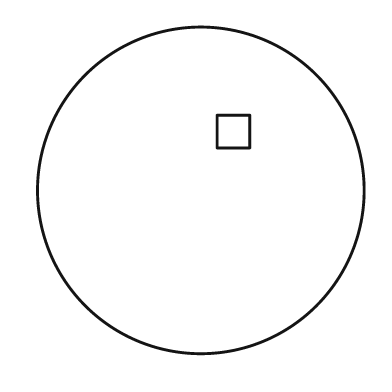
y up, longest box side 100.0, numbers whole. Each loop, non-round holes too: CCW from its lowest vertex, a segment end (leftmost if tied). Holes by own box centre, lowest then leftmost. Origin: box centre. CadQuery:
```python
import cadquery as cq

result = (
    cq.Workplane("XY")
    .moveTo(0.0, 0.0)
    .circle(50.0)
    .moveTo(5.0, 13.0)
    .lineTo(15.0, 13.0)
    .lineTo(15.0, 23.0)
    .lineTo(5.0, 23.0)
    .close()
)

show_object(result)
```